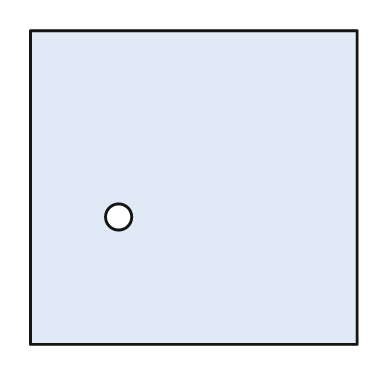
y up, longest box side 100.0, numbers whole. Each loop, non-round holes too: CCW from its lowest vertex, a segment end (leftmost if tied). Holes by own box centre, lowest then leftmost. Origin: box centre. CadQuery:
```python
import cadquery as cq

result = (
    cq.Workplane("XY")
    .moveTo(-50.0, -48.0)
    .lineTo(50.0, -48.0)
    .lineTo(50.0, 48.0)
    .lineTo(-50.0, 48.0)
    .close()
    .moveTo(-23.0, -9.0)
    .circle(4.0)
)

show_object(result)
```